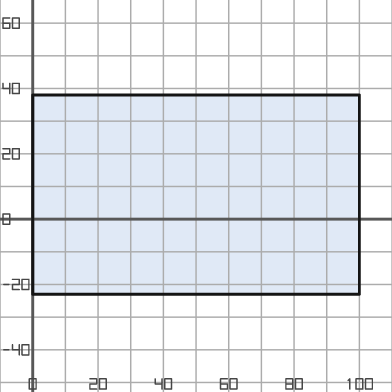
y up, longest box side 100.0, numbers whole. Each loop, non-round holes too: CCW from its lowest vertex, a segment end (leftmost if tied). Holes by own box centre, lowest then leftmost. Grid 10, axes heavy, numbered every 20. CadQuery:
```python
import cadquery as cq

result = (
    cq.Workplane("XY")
    .moveTo(0.0, -23.0)
    .lineTo(100.0, -23.0)
    .lineTo(100.0, 38.0)
    .lineTo(0.0, 38.0)
    .close()
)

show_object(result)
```